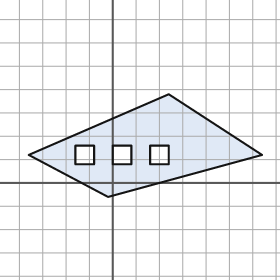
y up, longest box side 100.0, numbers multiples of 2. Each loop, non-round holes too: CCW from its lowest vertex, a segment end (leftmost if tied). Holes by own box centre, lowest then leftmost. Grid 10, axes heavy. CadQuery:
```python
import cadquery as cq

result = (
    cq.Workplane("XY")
    .moveTo(-2.0, -6.0)
    .lineTo(64.0, 12.0)
    .lineTo(24.0, 38.0)
    .lineTo(-36.0, 12.0)
    .close()
    .moveTo(-16.0, 8.0)
    .lineTo(-8.0, 8.0)
    .lineTo(-8.0, 16.0)
    .lineTo(-16.0, 16.0)
    .close()
    .moveTo(0.0, 8.0)
    .lineTo(8.0, 8.0)
    .lineTo(8.0, 16.0)
    .lineTo(0.0, 16.0)
    .close()
    .moveTo(16.0, 8.0)
    .lineTo(24.0, 8.0)
    .lineTo(24.0, 16.0)
    .lineTo(16.0, 16.0)
    .close()
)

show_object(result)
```